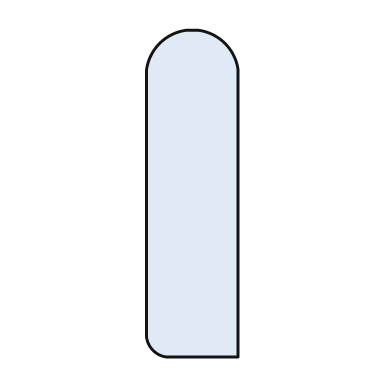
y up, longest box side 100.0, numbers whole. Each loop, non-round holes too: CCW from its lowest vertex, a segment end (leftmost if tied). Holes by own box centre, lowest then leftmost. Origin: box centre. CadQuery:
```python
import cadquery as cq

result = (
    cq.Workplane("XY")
    .moveTo(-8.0, -50.0)
    .lineTo(14.0, -50.0)
    .lineTo(14.0, 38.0)
    .threePointArc((10.0, 46.0), (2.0, 50.0))
    .lineTo(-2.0, 50.0)
    .threePointArc((-10.0, 46.0), (-14.0, 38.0))
    .lineTo(-14.0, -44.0)
    .threePointArc((-12.0, -48.0), (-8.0, -50.0))
    .close()
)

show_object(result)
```